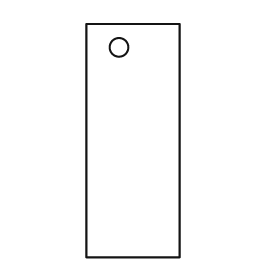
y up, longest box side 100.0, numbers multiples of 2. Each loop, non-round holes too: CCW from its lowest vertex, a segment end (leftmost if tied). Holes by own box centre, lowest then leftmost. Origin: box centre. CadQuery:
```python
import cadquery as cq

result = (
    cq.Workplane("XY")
    .moveTo(-20.0, -50.0)
    .lineTo(20.0, -50.0)
    .lineTo(20.0, 50.0)
    .lineTo(-20.0, 50.0)
    .close()
    .moveTo(-6.0, 40.0)
    .circle(4.0)
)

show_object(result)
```